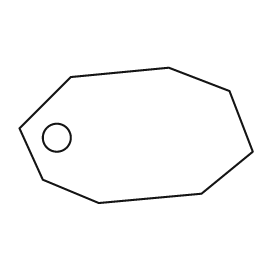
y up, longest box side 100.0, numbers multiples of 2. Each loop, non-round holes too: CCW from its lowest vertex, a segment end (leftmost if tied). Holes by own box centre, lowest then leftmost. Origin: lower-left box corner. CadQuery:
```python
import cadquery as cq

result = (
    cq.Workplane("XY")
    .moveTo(34.0, 0.0)
    .lineTo(78.0, 4.0)
    .lineTo(100.0, 22.0)
    .lineTo(90.0, 48.0)
    .lineTo(64.0, 58.0)
    .lineTo(22.0, 54.0)
    .lineTo(0.0, 32.0)
    .lineTo(10.0, 10.0)
    .close()
    .moveTo(16.0, 28.0)
    .circle(6.0)
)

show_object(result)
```